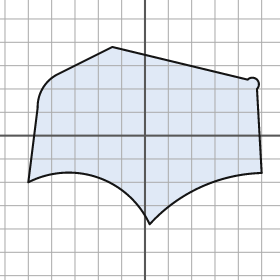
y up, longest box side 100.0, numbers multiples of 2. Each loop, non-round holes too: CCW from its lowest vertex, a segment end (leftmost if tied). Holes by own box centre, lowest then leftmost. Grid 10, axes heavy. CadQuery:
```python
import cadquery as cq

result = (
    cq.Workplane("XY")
    .moveTo(2.0, -38.0)
    .threePointArc((24.0, -22.0), (50.0, -16.0))
    .lineTo(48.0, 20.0)
    .threePointArc((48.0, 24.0), (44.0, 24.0))
    .lineTo(-14.0, 38.0)
    .lineTo(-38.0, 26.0)
    .threePointArc((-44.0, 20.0), (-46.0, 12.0))
    .lineTo(-50.0, -20.0)
    .threePointArc((-20.0, -18.0), (2.0, -38.0))
    .close()
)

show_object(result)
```